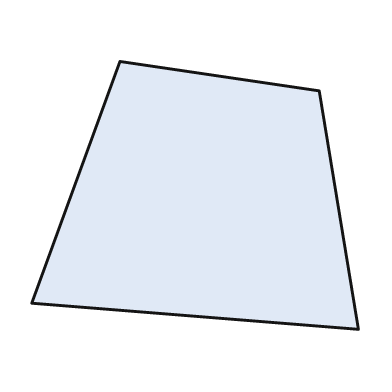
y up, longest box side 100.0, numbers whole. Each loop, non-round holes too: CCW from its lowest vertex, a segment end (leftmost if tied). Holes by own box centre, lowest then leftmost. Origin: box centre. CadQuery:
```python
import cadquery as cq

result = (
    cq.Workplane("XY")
    .moveTo(50.0, -41.0)
    .lineTo(38.0, 32.0)
    .lineTo(-23.0, 41.0)
    .lineTo(-50.0, -33.0)
    .close()
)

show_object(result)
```